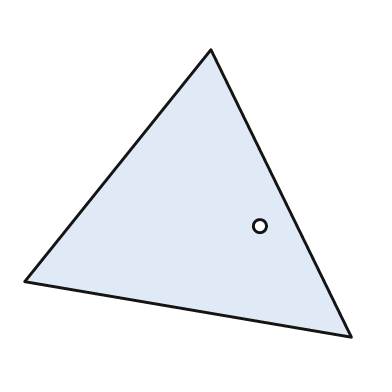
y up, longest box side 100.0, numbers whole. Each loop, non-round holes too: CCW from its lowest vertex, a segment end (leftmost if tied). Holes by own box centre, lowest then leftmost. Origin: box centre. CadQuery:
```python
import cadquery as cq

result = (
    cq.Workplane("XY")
    .moveTo(50.0, -44.0)
    .lineTo(7.0, 44.0)
    .lineTo(-50.0, -27.0)
    .close()
    .moveTo(22.0, -10.0)
    .circle(2.0)
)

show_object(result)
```